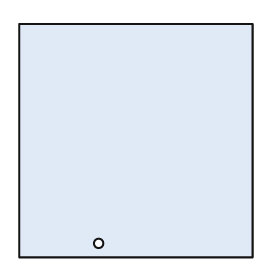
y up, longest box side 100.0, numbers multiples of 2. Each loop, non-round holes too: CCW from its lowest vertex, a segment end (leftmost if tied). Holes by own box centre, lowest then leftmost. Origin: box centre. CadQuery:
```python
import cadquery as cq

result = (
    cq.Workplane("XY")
    .moveTo(-50.0, -50.0)
    .lineTo(50.0, -50.0)
    .lineTo(50.0, 50.0)
    .lineTo(-50.0, 50.0)
    .close()
    .moveTo(-16.0, -44.0)
    .circle(2.0)
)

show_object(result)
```